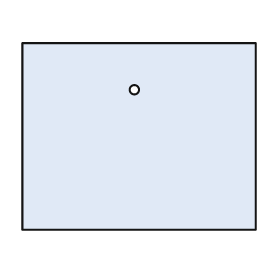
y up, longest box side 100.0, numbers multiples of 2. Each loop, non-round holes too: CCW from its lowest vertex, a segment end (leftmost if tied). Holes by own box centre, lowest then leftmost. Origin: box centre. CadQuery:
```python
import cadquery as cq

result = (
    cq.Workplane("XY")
    .moveTo(-50.0, -40.0)
    .lineTo(50.0, -40.0)
    .lineTo(50.0, 40.0)
    .lineTo(-50.0, 40.0)
    .close()
    .moveTo(-2.0, 20.0)
    .circle(2.0)
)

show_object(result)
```